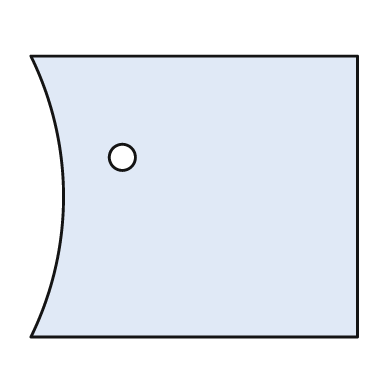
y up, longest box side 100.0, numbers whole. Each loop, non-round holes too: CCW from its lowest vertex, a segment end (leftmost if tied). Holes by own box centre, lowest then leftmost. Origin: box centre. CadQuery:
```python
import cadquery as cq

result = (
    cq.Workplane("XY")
    .moveTo(-50.0, -43.0)
    .lineTo(50.0, -43.0)
    .lineTo(50.0, 43.0)
    .lineTo(-50.0, 43.0)
    .threePointArc((-40.0, 0.0), (-50.0, -43.0))
    .close()
    .moveTo(-22.0, 12.0)
    .circle(4.0)
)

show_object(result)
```